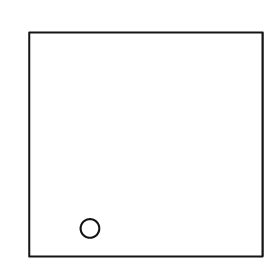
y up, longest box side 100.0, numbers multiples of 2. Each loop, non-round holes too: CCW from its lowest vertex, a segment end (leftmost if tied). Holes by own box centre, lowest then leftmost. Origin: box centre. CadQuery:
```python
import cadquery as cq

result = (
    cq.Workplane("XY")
    .moveTo(-50.0, -48.0)
    .lineTo(50.0, -48.0)
    .lineTo(50.0, 48.0)
    .lineTo(-50.0, 48.0)
    .close()
    .moveTo(-24.0, -36.0)
    .circle(4.0)
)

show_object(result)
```